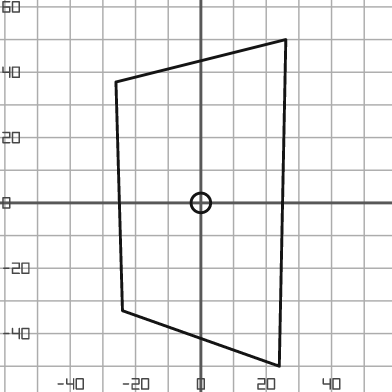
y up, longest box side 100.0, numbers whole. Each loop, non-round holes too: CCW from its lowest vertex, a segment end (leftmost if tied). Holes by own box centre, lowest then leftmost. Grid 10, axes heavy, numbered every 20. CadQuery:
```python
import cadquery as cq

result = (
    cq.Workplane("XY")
    .moveTo(24.0, -50.0)
    .lineTo(26.0, 50.0)
    .lineTo(-26.0, 37.0)
    .lineTo(-24.0, -33.0)
    .close()
    .moveTo(0.0, 0.0)
    .circle(3.0)
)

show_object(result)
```